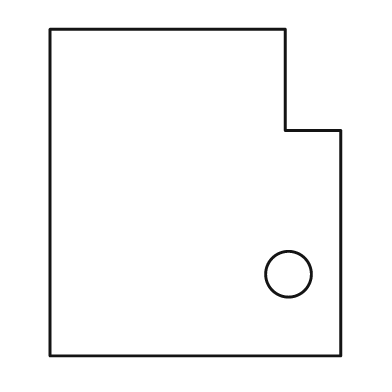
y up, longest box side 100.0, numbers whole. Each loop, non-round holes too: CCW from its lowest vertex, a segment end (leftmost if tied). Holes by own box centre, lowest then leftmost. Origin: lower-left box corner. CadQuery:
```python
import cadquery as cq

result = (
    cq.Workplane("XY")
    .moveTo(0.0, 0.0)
    .lineTo(89.0, 0.0)
    .lineTo(89.0, 69.0)
    .lineTo(72.0, 69.0)
    .lineTo(72.0, 100.0)
    .lineTo(0.0, 100.0)
    .close()
    .moveTo(73.0, 25.0)
    .circle(7.0)
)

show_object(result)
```